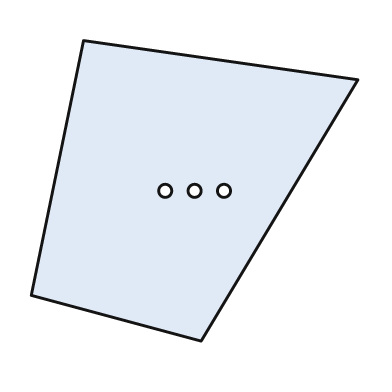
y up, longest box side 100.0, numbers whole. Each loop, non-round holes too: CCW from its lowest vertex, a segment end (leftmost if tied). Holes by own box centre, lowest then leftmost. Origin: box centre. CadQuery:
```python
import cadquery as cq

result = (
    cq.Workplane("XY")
    .moveTo(2.0, -46.0)
    .lineTo(50.0, 34.0)
    .lineTo(-34.0, 46.0)
    .lineTo(-50.0, -32.0)
    .close()
    .moveTo(-9.0, 0.0)
    .circle(2.0)
    .moveTo(0.0, 0.0)
    .circle(2.0)
    .moveTo(9.0, 0.0)
    .circle(2.0)
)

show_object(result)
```